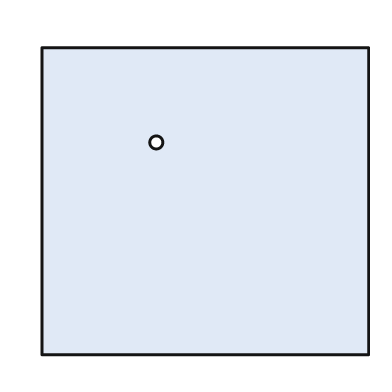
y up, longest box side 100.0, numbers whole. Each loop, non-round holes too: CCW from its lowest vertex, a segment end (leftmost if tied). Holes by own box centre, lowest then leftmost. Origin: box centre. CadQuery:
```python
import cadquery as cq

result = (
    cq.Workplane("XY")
    .moveTo(-50.0, -47.0)
    .lineTo(50.0, -47.0)
    .lineTo(50.0, 47.0)
    .lineTo(-50.0, 47.0)
    .close()
    .moveTo(-15.0, 18.0)
    .circle(2.0)
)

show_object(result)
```